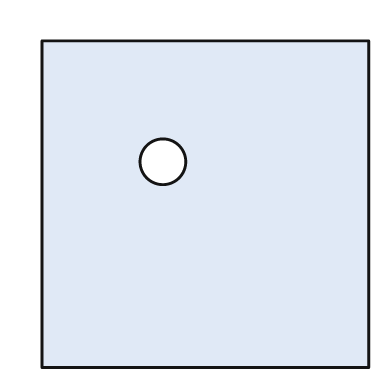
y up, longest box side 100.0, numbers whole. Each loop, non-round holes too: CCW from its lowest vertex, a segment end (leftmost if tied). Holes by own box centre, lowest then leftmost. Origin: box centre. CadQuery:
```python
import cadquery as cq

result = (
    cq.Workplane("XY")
    .moveTo(-50.0, -50.0)
    .lineTo(50.0, -50.0)
    .lineTo(50.0, 50.0)
    .lineTo(-50.0, 50.0)
    .close()
    .moveTo(-13.0, 13.0)
    .circle(7.0)
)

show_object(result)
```